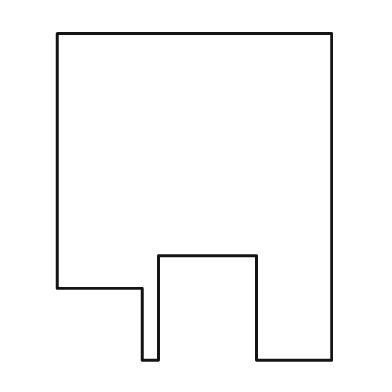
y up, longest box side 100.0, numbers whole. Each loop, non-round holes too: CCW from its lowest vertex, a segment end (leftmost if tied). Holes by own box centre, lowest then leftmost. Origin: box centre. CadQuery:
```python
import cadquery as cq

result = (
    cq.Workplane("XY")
    .moveTo(-16.0, -50.0)
    .lineTo(-11.0, -50.0)
    .lineTo(-11.0, -18.0)
    .lineTo(19.0, -18.0)
    .lineTo(19.0, -50.0)
    .lineTo(42.0, -50.0)
    .lineTo(42.0, 50.0)
    .lineTo(-42.0, 50.0)
    .lineTo(-42.0, -28.0)
    .lineTo(-16.0, -28.0)
    .close()
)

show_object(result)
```